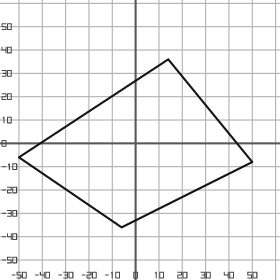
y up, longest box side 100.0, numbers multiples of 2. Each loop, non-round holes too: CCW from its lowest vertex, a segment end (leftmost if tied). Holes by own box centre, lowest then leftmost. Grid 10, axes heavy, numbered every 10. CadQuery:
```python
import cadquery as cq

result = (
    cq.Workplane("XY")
    .moveTo(-6.0, -36.0)
    .lineTo(50.0, -8.0)
    .lineTo(14.0, 36.0)
    .lineTo(-50.0, -6.0)
    .close()
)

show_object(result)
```